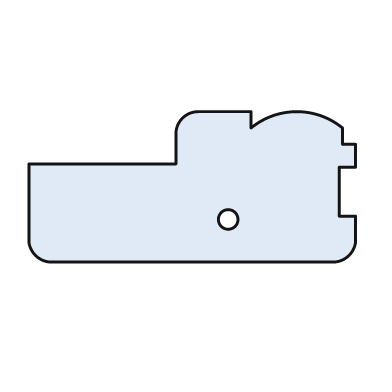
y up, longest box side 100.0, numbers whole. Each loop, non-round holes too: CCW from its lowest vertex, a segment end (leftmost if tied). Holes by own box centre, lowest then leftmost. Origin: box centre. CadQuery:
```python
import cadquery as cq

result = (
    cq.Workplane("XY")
    .moveTo(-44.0, -23.0)
    .lineTo(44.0, -23.0)
    .threePointArc((48.0, -21.0), (50.0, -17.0))
    .lineTo(50.0, -9.0)
    .lineTo(45.0, -9.0)
    .lineTo(45.0, 6.0)
    .lineTo(50.0, 6.0)
    .lineTo(50.0, 13.0)
    .lineTo(46.0, 13.0)
    .lineTo(46.0, 18.0)
    .threePointArc((32.0, 23.0), (18.0, 18.0))
    .lineTo(18.0, 23.0)
    .lineTo(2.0, 23.0)
    .threePointArc((-3.0, 21.0), (-5.0, 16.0))
    .lineTo(-5.0, 7.0)
    .lineTo(-50.0, 7.0)
    .lineTo(-50.0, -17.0)
    .threePointArc((-48.0, -21.0), (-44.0, -23.0))
    .close()
    .moveTo(11.0, -10.0)
    .circle(3.0)
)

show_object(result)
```